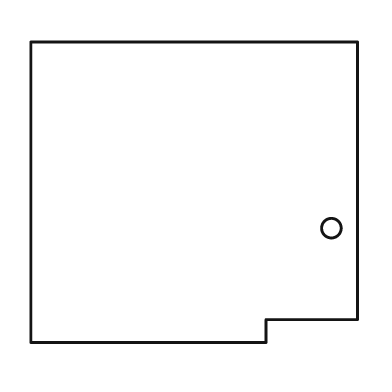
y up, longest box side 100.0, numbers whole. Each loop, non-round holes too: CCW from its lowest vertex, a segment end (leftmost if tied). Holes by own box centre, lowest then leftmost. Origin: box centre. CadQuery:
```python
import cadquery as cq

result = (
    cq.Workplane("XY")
    .moveTo(-50.0, -46.0)
    .lineTo(22.0, -46.0)
    .lineTo(22.0, -39.0)
    .lineTo(50.0, -39.0)
    .lineTo(50.0, 46.0)
    .lineTo(-50.0, 46.0)
    .close()
    .moveTo(42.0, -11.0)
    .circle(3.0)
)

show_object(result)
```